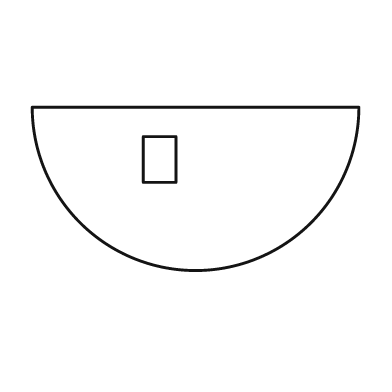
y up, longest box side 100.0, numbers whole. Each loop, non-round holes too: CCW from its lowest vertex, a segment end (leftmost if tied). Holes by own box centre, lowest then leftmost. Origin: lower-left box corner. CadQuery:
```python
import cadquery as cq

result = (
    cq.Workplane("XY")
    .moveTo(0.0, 50.0)
    .threePointArc((50.0, 0.0), (100.0, 50.0))
    .close()
    .moveTo(34.0, 27.0)
    .lineTo(44.0, 27.0)
    .lineTo(44.0, 41.0)
    .lineTo(34.0, 41.0)
    .close()
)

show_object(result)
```